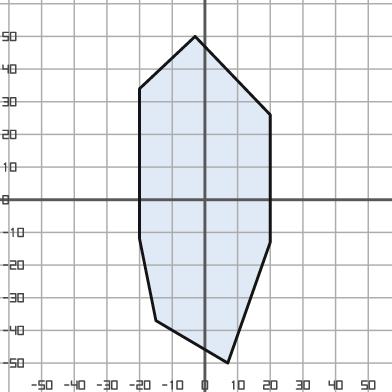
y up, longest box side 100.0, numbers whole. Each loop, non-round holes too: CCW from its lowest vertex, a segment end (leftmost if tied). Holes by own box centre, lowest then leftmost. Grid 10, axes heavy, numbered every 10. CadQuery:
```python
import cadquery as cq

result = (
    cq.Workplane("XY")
    .moveTo(7.0, -50.0)
    .lineTo(20.0, -13.0)
    .lineTo(20.0, 26.0)
    .lineTo(-3.0, 50.0)
    .lineTo(-20.0, 34.0)
    .lineTo(-20.0, -12.0)
    .lineTo(-15.0, -37.0)
    .close()
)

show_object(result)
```